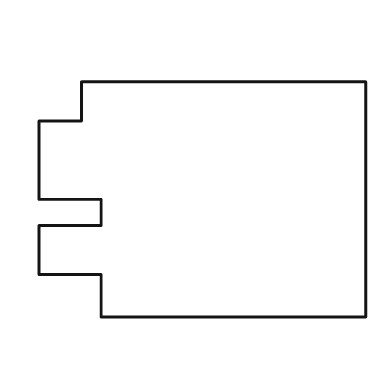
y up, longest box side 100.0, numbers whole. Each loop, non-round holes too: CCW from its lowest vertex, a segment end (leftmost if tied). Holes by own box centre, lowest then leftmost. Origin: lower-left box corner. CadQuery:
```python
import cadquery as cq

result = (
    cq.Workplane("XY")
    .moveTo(19.0, 0.0)
    .lineTo(100.0, 0.0)
    .lineTo(100.0, 72.0)
    .lineTo(13.0, 72.0)
    .lineTo(13.0, 60.0)
    .lineTo(0.0, 60.0)
    .lineTo(0.0, 36.0)
    .lineTo(19.0, 36.0)
    .lineTo(19.0, 28.0)
    .lineTo(0.0, 28.0)
    .lineTo(0.0, 13.0)
    .lineTo(19.0, 13.0)
    .close()
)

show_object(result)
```